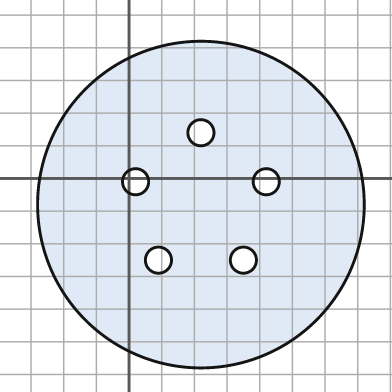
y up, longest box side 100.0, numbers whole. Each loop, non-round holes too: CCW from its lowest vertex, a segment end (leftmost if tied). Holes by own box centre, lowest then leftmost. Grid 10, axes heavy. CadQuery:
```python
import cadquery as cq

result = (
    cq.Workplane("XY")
    .moveTo(22.0, -8.0)
    .circle(50.0)
    .moveTo(9.0, -25.0)
    .circle(4.0)
    .moveTo(35.0, -25.0)
    .circle(4.0)
    .moveTo(2.0, -1.0)
    .circle(4.0)
    .moveTo(42.0, -1.0)
    .circle(4.0)
    .moveTo(22.0, 14.0)
    .circle(4.0)
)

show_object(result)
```